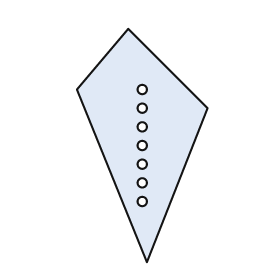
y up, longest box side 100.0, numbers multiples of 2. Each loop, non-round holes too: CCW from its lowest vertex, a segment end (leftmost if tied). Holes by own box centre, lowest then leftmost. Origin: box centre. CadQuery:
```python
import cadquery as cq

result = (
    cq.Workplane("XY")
    .moveTo(2.0, -50.0)
    .lineTo(28.0, 16.0)
    .lineTo(-6.0, 50.0)
    .lineTo(-28.0, 24.0)
    .close()
    .moveTo(0.0, -24.0)
    .circle(2.0)
    .moveTo(0.0, -16.0)
    .circle(2.0)
    .moveTo(0.0, -8.0)
    .circle(2.0)
    .moveTo(0.0, 0.0)
    .circle(2.0)
    .moveTo(0.0, 8.0)
    .circle(2.0)
    .moveTo(0.0, 16.0)
    .circle(2.0)
    .moveTo(0.0, 24.0)
    .circle(2.0)
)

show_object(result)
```